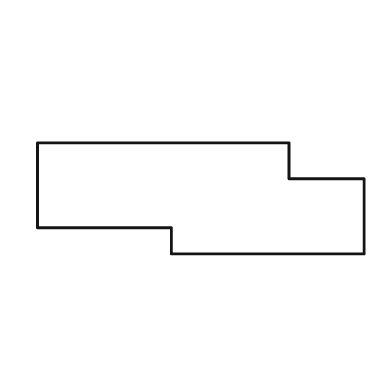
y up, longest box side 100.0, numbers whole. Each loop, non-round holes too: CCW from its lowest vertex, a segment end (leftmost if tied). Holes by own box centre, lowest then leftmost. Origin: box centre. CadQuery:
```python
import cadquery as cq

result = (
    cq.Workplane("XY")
    .moveTo(-9.0, -17.0)
    .lineTo(50.0, -17.0)
    .lineTo(50.0, 6.0)
    .lineTo(27.0, 6.0)
    .lineTo(27.0, 17.0)
    .lineTo(-50.0, 17.0)
    .lineTo(-50.0, -9.0)
    .lineTo(-9.0, -9.0)
    .close()
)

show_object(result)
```